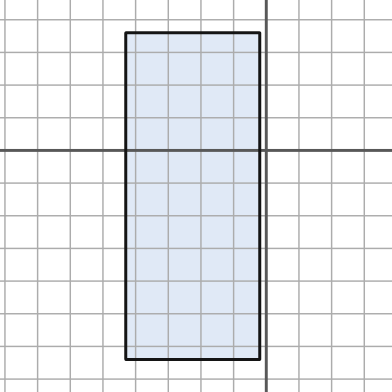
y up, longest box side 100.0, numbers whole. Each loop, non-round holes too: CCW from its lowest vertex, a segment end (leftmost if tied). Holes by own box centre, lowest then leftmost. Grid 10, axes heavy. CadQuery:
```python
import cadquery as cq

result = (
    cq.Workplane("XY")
    .moveTo(-43.0, -64.0)
    .lineTo(-2.0, -64.0)
    .lineTo(-2.0, 36.0)
    .lineTo(-43.0, 36.0)
    .close()
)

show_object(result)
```